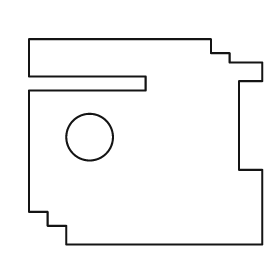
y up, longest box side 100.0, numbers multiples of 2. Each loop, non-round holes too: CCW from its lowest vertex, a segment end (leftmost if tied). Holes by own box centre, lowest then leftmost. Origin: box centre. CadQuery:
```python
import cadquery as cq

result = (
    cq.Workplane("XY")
    .moveTo(-34.0, -44.0)
    .lineTo(50.0, -44.0)
    .lineTo(50.0, -12.0)
    .lineTo(40.0, -12.0)
    .lineTo(40.0, 26.0)
    .lineTo(50.0, 26.0)
    .lineTo(50.0, 34.0)
    .lineTo(36.0, 34.0)
    .lineTo(36.0, 38.0)
    .lineTo(28.0, 38.0)
    .lineTo(28.0, 44.0)
    .lineTo(-50.0, 44.0)
    .lineTo(-50.0, 28.0)
    .lineTo(0.0, 28.0)
    .lineTo(0.0, 22.0)
    .lineTo(-50.0, 22.0)
    .lineTo(-50.0, -30.0)
    .lineTo(-42.0, -30.0)
    .lineTo(-42.0, -36.0)
    .lineTo(-34.0, -36.0)
    .close()
    .moveTo(-24.0, 2.0)
    .circle(10.0)
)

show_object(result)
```